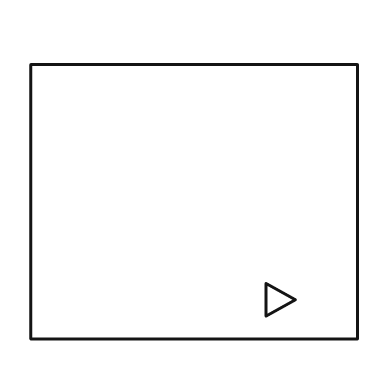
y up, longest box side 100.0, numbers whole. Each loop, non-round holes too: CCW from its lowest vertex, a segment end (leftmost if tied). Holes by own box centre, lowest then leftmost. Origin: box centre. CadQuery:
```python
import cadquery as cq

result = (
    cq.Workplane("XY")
    .moveTo(-50.0, -42.0)
    .lineTo(50.0, -42.0)
    .lineTo(50.0, 42.0)
    .lineTo(-50.0, 42.0)
    .close()
    .moveTo(22.0, -35.0)
    .lineTo(31.0, -30.0)
    .lineTo(22.0, -25.0)
    .close()
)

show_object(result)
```